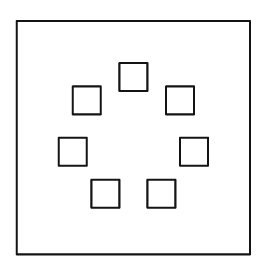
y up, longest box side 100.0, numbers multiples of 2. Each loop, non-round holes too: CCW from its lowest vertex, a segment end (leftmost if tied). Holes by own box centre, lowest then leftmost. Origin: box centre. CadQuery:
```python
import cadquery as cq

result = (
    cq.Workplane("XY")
    .moveTo(-50.0, -50.0)
    .lineTo(50.0, -50.0)
    .lineTo(50.0, 50.0)
    .lineTo(-50.0, 50.0)
    .close()
    .moveTo(-18.0, -30.0)
    .lineTo(-6.0, -30.0)
    .lineTo(-6.0, -18.0)
    .lineTo(-18.0, -18.0)
    .close()
    .moveTo(6.0, -30.0)
    .lineTo(18.0, -30.0)
    .lineTo(18.0, -18.0)
    .lineTo(6.0, -18.0)
    .close()
    .moveTo(-32.0, -12.0)
    .lineTo(-20.0, -12.0)
    .lineTo(-20.0, 0.0)
    .lineTo(-32.0, 0.0)
    .close()
    .moveTo(20.0, -12.0)
    .lineTo(32.0, -12.0)
    .lineTo(32.0, 0.0)
    .lineTo(20.0, 0.0)
    .close()
    .moveTo(-26.0, 10.0)
    .lineTo(-14.0, 10.0)
    .lineTo(-14.0, 22.0)
    .lineTo(-26.0, 22.0)
    .close()
    .moveTo(14.0, 10.0)
    .lineTo(26.0, 10.0)
    .lineTo(26.0, 22.0)
    .lineTo(14.0, 22.0)
    .close()
    .moveTo(-6.0, 20.0)
    .lineTo(6.0, 20.0)
    .lineTo(6.0, 32.0)
    .lineTo(-6.0, 32.0)
    .close()
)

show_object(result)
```